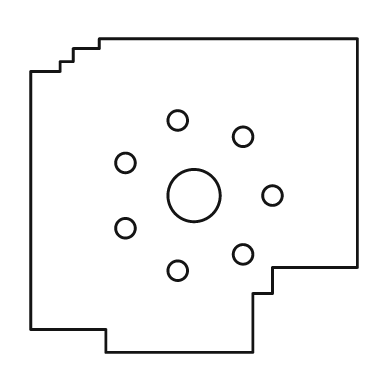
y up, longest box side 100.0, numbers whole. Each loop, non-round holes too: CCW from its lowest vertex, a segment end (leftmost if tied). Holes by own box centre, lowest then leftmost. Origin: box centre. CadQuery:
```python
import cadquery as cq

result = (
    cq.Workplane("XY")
    .moveTo(-27.0, -48.0)
    .lineTo(18.0, -48.0)
    .lineTo(18.0, -30.0)
    .lineTo(24.0, -30.0)
    .lineTo(24.0, -22.0)
    .lineTo(50.0, -22.0)
    .lineTo(50.0, 48.0)
    .lineTo(-29.0, 48.0)
    .lineTo(-29.0, 45.0)
    .lineTo(-37.0, 45.0)
    .lineTo(-37.0, 41.0)
    .lineTo(-41.0, 41.0)
    .lineTo(-41.0, 38.0)
    .lineTo(-50.0, 38.0)
    .lineTo(-50.0, -41.0)
    .lineTo(-27.0, -41.0)
    .close()
    .moveTo(-5.0, -23.0)
    .circle(3.0)
    .moveTo(15.0, -18.0)
    .circle(3.0)
    .moveTo(-21.0, -10.0)
    .circle(3.0)
    .moveTo(0.0, 0.0)
    .circle(8.0)
    .moveTo(24.0, 0.0)
    .circle(3.0)
    .moveTo(-21.0, 10.0)
    .circle(3.0)
    .moveTo(15.0, 18.0)
    .circle(3.0)
    .moveTo(-5.0, 23.0)
    .circle(3.0)
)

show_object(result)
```